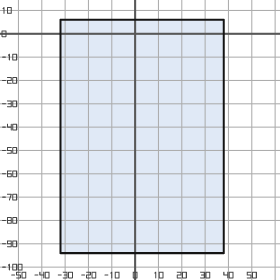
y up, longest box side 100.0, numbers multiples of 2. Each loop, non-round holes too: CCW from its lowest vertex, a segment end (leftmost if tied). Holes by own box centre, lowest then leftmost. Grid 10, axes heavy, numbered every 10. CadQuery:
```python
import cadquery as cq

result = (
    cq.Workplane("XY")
    .moveTo(-32.0, -94.0)
    .lineTo(38.0, -94.0)
    .lineTo(38.0, 6.0)
    .lineTo(-32.0, 6.0)
    .close()
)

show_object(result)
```